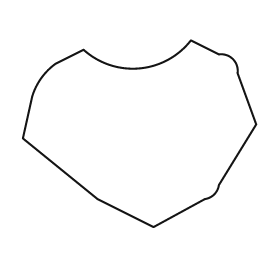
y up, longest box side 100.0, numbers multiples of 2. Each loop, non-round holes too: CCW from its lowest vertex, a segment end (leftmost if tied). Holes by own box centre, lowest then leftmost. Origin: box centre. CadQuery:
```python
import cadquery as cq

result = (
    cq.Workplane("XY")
    .moveTo(6.0, -40.0)
    .lineTo(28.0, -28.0)
    .threePointArc((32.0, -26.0), (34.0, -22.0))
    .lineTo(50.0, 4.0)
    .lineTo(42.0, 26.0)
    .threePointArc((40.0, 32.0), (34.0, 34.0))
    .lineTo(22.0, 40.0)
    .threePointArc((0.0, 28.0), (-24.0, 36.0))
    .lineTo(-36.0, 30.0)
    .threePointArc((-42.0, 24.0), (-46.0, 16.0))
    .lineTo(-50.0, -2.0)
    .lineTo(-18.0, -28.0)
    .close()
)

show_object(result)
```